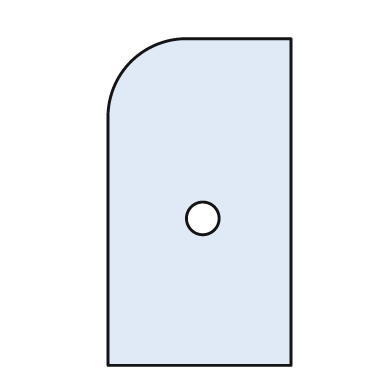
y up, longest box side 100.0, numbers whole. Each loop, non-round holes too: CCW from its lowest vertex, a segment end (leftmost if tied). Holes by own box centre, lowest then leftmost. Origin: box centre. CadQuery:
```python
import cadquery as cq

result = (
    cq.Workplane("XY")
    .moveTo(-28.0, -50.0)
    .lineTo(28.0, -50.0)
    .lineTo(28.0, 50.0)
    .lineTo(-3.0, 50.0)
    .threePointArc((-21.0, 43.0), (-28.0, 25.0))
    .close()
    .moveTo(1.0, -5.0)
    .circle(5.0)
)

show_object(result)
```